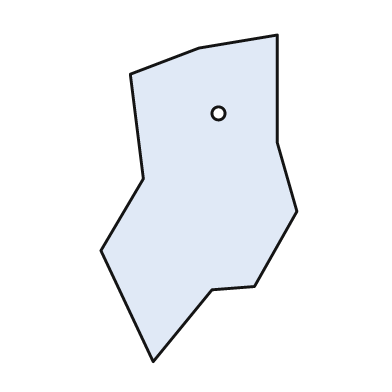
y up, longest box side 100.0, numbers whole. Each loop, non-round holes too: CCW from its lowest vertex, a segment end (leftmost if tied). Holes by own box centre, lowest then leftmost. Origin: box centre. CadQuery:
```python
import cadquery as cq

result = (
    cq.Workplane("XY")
    .moveTo(-14.0, -50.0)
    .lineTo(4.0, -28.0)
    .lineTo(17.0, -27.0)
    .lineTo(30.0, -4.0)
    .lineTo(24.0, 17.0)
    .lineTo(24.0, 50.0)
    .lineTo(0.0, 46.0)
    .lineTo(-21.0, 38.0)
    .lineTo(-17.0, 6.0)
    .lineTo(-30.0, -16.0)
    .close()
    .moveTo(6.0, 26.0)
    .circle(2.0)
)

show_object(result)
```